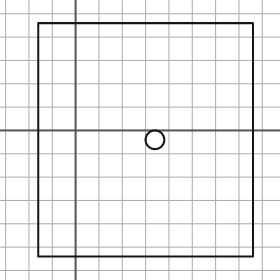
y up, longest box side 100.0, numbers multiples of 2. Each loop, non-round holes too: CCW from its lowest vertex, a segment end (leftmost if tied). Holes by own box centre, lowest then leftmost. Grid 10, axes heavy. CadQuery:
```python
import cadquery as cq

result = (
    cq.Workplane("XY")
    .moveTo(-16.0, -54.0)
    .lineTo(76.0, -54.0)
    .lineTo(76.0, 46.0)
    .lineTo(-16.0, 46.0)
    .close()
    .moveTo(34.0, -4.0)
    .circle(4.0)
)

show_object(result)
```